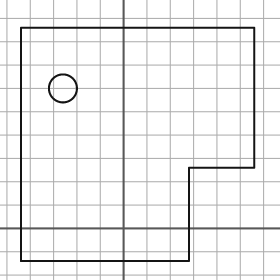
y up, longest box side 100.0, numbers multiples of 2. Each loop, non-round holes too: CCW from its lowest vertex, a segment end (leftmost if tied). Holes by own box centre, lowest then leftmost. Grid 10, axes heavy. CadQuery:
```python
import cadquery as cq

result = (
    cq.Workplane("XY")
    .moveTo(-44.0, -14.0)
    .lineTo(28.0, -14.0)
    .lineTo(28.0, 26.0)
    .lineTo(56.0, 26.0)
    .lineTo(56.0, 86.0)
    .lineTo(-44.0, 86.0)
    .close()
    .moveTo(-26.0, 60.0)
    .circle(6.0)
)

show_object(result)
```